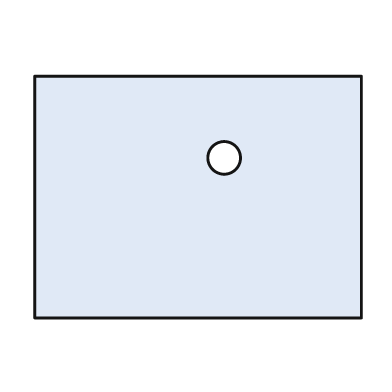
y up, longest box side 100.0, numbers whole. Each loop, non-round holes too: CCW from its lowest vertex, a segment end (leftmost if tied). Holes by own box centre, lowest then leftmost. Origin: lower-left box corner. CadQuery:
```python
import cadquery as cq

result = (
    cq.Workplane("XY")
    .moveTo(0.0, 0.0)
    .lineTo(100.0, 0.0)
    .lineTo(100.0, 74.0)
    .lineTo(0.0, 74.0)
    .close()
    .moveTo(58.0, 49.0)
    .circle(5.0)
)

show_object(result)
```